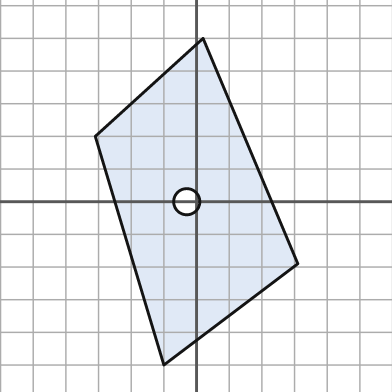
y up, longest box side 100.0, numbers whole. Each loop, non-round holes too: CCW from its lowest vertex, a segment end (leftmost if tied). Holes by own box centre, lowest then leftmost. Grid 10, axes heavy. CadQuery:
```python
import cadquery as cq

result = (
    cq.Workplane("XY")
    .moveTo(-10.0, -50.0)
    .lineTo(31.0, -19.0)
    .lineTo(2.0, 50.0)
    .lineTo(-31.0, 20.0)
    .close()
    .moveTo(-3.0, 0.0)
    .circle(4.0)
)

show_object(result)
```